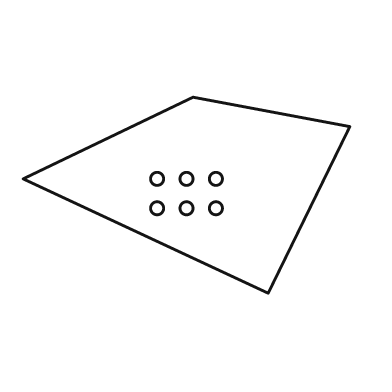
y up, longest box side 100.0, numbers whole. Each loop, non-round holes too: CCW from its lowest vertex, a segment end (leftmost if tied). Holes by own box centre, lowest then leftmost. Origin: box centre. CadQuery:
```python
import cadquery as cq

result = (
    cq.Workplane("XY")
    .moveTo(25.0, -30.0)
    .lineTo(50.0, 21.0)
    .lineTo(2.0, 30.0)
    .lineTo(-50.0, 5.0)
    .close()
    .moveTo(-9.0, -4.0)
    .circle(2.0)
    .moveTo(0.0, -4.0)
    .circle(2.0)
    .moveTo(9.0, -4.0)
    .circle(2.0)
    .moveTo(-9.0, 5.0)
    .circle(2.0)
    .moveTo(0.0, 5.0)
    .circle(2.0)
    .moveTo(9.0, 5.0)
    .circle(2.0)
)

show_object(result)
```